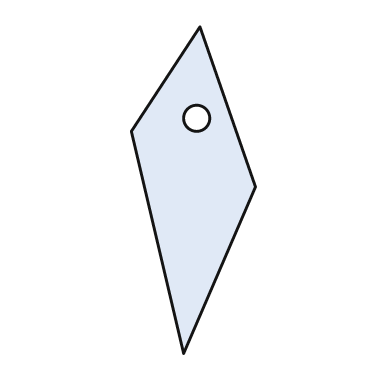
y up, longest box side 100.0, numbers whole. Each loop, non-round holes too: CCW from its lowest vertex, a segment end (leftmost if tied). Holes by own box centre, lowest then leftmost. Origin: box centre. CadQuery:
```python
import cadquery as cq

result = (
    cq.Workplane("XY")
    .moveTo(-3.0, -50.0)
    .lineTo(19.0, 1.0)
    .lineTo(2.0, 50.0)
    .lineTo(-19.0, 18.0)
    .close()
    .moveTo(1.0, 22.0)
    .circle(4.0)
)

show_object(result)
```